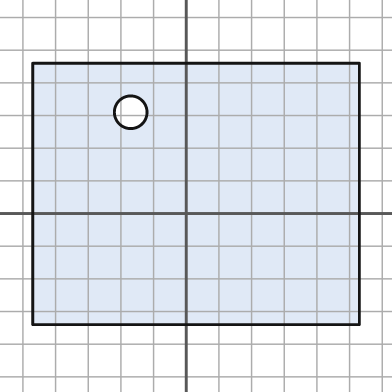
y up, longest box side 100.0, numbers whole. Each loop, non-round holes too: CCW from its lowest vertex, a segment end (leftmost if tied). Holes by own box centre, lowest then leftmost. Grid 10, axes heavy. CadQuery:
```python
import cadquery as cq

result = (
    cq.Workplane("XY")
    .moveTo(-47.0, -34.0)
    .lineTo(53.0, -34.0)
    .lineTo(53.0, 46.0)
    .lineTo(-47.0, 46.0)
    .close()
    .moveTo(-17.0, 31.0)
    .circle(5.0)
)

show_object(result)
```